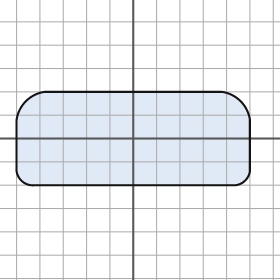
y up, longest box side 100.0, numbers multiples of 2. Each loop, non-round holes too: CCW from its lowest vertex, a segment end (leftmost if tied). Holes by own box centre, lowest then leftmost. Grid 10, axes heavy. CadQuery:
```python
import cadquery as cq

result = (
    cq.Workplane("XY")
    .moveTo(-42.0, -20.0)
    .lineTo(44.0, -20.0)
    .threePointArc((48.0, -18.0), (50.0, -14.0))
    .lineTo(50.0, 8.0)
    .threePointArc((46.0, 16.0), (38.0, 20.0))
    .lineTo(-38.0, 20.0)
    .threePointArc((-46.0, 16.0), (-50.0, 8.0))
    .lineTo(-50.0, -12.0)
    .threePointArc((-48.0, -18.0), (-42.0, -20.0))
    .close()
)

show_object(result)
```